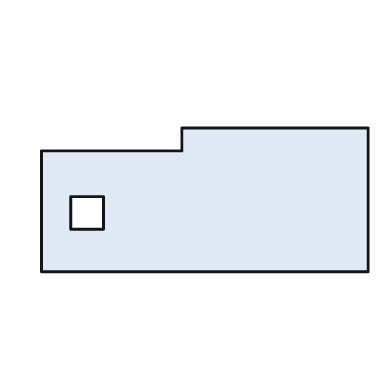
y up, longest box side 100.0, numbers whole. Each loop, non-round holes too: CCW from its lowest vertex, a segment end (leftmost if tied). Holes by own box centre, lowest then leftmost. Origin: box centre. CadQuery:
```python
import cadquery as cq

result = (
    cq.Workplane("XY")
    .moveTo(-50.0, -22.0)
    .lineTo(50.0, -22.0)
    .lineTo(50.0, 22.0)
    .lineTo(-7.0, 22.0)
    .lineTo(-7.0, 15.0)
    .lineTo(-50.0, 15.0)
    .close()
    .moveTo(-41.0, -9.0)
    .lineTo(-31.0, -9.0)
    .lineTo(-31.0, 1.0)
    .lineTo(-41.0, 1.0)
    .close()
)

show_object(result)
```